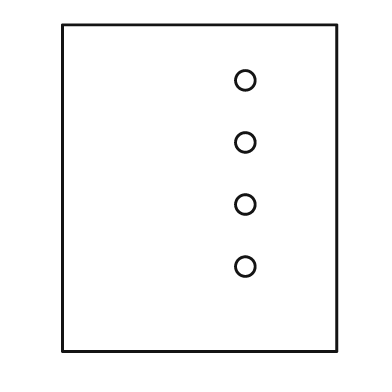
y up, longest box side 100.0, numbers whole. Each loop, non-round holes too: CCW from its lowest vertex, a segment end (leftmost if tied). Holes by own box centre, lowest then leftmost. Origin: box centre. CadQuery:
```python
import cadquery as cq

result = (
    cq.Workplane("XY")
    .moveTo(-42.0, -50.0)
    .lineTo(42.0, -50.0)
    .lineTo(42.0, 50.0)
    .lineTo(-42.0, 50.0)
    .close()
    .moveTo(14.0, -24.0)
    .circle(3.0)
    .moveTo(14.0, -5.0)
    .circle(3.0)
    .moveTo(14.0, 14.0)
    .circle(3.0)
    .moveTo(14.0, 33.0)
    .circle(3.0)
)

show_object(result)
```